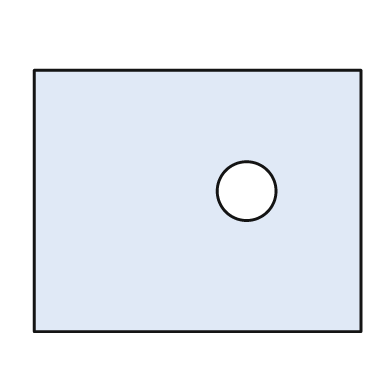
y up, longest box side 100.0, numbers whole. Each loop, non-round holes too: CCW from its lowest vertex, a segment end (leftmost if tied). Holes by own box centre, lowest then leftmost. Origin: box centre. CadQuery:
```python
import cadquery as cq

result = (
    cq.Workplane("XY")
    .moveTo(-50.0, -40.0)
    .lineTo(50.0, -40.0)
    .lineTo(50.0, 40.0)
    .lineTo(-50.0, 40.0)
    .close()
    .moveTo(15.0, 3.0)
    .circle(9.0)
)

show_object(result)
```